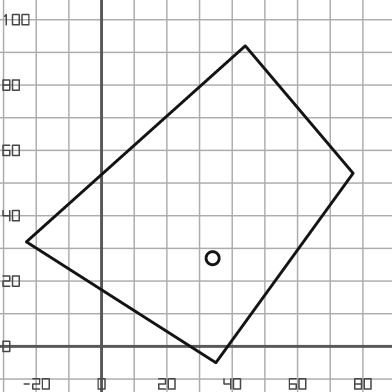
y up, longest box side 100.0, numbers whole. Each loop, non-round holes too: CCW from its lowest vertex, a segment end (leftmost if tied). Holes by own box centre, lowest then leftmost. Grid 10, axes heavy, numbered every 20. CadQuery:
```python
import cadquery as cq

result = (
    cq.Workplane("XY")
    .moveTo(35.0, -5.0)
    .lineTo(77.0, 53.0)
    .lineTo(44.0, 92.0)
    .lineTo(-23.0, 32.0)
    .close()
    .moveTo(34.0, 27.0)
    .circle(2.0)
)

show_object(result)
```